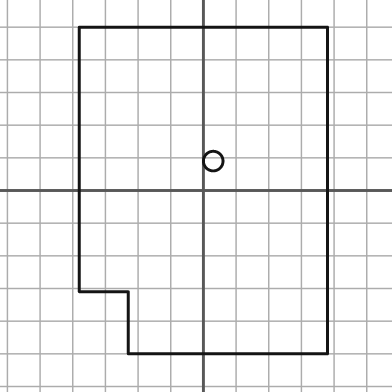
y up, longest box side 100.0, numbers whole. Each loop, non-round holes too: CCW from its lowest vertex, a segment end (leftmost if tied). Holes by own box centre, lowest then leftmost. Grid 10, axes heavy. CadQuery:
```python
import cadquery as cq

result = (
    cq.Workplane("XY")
    .moveTo(-23.0, -50.0)
    .lineTo(38.0, -50.0)
    .lineTo(38.0, 50.0)
    .lineTo(-38.0, 50.0)
    .lineTo(-38.0, -31.0)
    .lineTo(-23.0, -31.0)
    .close()
    .moveTo(3.0, 9.0)
    .circle(3.0)
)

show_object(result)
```